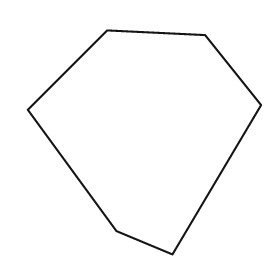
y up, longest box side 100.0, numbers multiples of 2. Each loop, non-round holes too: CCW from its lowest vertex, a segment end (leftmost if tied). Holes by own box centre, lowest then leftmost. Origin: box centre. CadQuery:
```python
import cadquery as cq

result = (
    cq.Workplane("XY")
    .moveTo(12.0, -48.0)
    .lineTo(50.0, 16.0)
    .lineTo(26.0, 46.0)
    .lineTo(-16.0, 48.0)
    .lineTo(-50.0, 14.0)
    .lineTo(-12.0, -38.0)
    .close()
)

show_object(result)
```